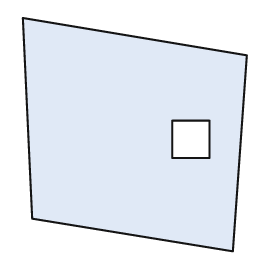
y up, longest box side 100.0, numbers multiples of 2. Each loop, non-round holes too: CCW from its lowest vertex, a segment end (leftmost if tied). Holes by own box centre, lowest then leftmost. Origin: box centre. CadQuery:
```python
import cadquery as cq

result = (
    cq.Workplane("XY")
    .moveTo(42.0, -50.0)
    .lineTo(48.0, 34.0)
    .lineTo(-48.0, 50.0)
    .lineTo(-44.0, -36.0)
    .close()
    .moveTo(16.0, -10.0)
    .lineTo(32.0, -10.0)
    .lineTo(32.0, 6.0)
    .lineTo(16.0, 6.0)
    .close()
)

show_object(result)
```